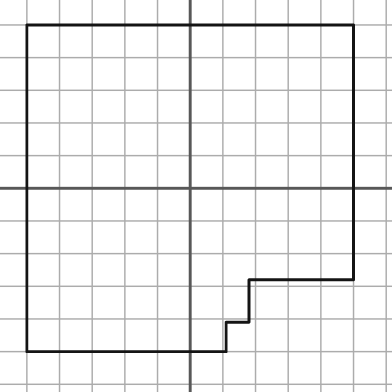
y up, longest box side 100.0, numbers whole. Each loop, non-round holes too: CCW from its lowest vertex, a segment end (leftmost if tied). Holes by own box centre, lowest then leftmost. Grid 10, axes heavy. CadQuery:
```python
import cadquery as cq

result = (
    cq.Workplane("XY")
    .moveTo(-50.0, -50.0)
    .lineTo(11.0, -50.0)
    .lineTo(11.0, -41.0)
    .lineTo(18.0, -41.0)
    .lineTo(18.0, -28.0)
    .lineTo(50.0, -28.0)
    .lineTo(50.0, 50.0)
    .lineTo(-50.0, 50.0)
    .close()
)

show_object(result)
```